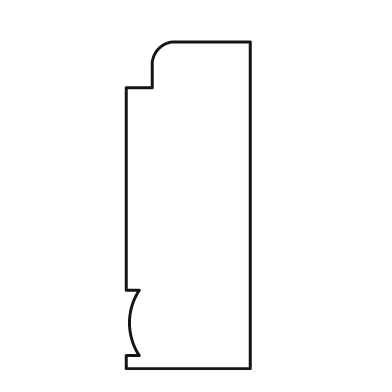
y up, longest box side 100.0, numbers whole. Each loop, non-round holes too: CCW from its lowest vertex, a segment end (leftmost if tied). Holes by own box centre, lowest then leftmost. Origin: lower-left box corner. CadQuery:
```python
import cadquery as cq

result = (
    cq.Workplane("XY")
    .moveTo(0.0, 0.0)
    .lineTo(38.0, 0.0)
    .lineTo(38.0, 100.0)
    .lineTo(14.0, 100.0)
    .threePointArc((10.0, 98.0), (8.0, 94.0))
    .lineTo(8.0, 86.0)
    .lineTo(0.0, 86.0)
    .lineTo(0.0, 24.0)
    .lineTo(4.0, 24.0)
    .threePointArc((1.0, 14.0), (4.0, 4.0))
    .lineTo(0.0, 4.0)
    .close()
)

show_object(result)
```